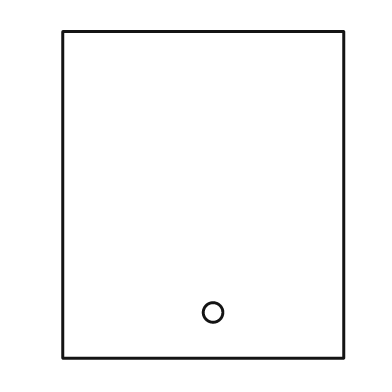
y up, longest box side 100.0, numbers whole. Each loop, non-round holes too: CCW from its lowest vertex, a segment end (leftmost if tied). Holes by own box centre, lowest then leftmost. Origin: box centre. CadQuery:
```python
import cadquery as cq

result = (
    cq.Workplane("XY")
    .moveTo(-43.0, -50.0)
    .lineTo(43.0, -50.0)
    .lineTo(43.0, 50.0)
    .lineTo(-43.0, 50.0)
    .close()
    .moveTo(3.0, -36.0)
    .circle(3.0)
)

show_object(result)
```